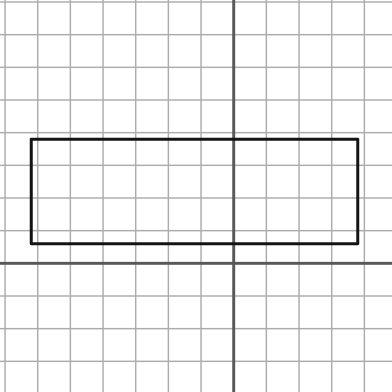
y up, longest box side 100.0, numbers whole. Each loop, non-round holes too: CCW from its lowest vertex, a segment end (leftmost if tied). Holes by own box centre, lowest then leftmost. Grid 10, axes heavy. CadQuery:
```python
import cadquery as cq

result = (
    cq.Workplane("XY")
    .moveTo(-62.0, 6.0)
    .lineTo(38.0, 6.0)
    .lineTo(38.0, 38.0)
    .lineTo(-62.0, 38.0)
    .close()
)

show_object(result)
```